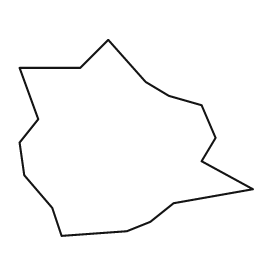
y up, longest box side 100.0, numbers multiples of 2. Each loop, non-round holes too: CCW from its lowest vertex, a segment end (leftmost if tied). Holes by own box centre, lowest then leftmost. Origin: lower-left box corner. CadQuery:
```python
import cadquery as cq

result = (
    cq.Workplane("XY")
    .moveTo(18.0, 0.0)
    .lineTo(46.0, 2.0)
    .lineTo(56.0, 6.0)
    .lineTo(66.0, 14.0)
    .lineTo(100.0, 20.0)
    .lineTo(78.0, 32.0)
    .lineTo(84.0, 42.0)
    .lineTo(78.0, 56.0)
    .lineTo(64.0, 60.0)
    .lineTo(54.0, 66.0)
    .lineTo(38.0, 84.0)
    .lineTo(26.0, 72.0)
    .lineTo(0.0, 72.0)
    .lineTo(8.0, 50.0)
    .lineTo(0.0, 40.0)
    .lineTo(2.0, 26.0)
    .lineTo(14.0, 12.0)
    .close()
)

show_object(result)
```